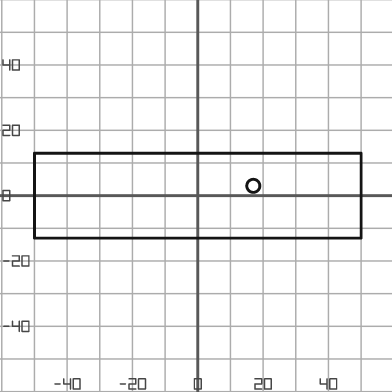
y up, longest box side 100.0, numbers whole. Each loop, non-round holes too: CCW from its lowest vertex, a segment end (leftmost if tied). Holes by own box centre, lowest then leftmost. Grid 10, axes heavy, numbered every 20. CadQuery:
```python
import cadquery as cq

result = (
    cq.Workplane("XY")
    .moveTo(-50.0, -13.0)
    .lineTo(50.0, -13.0)
    .lineTo(50.0, 13.0)
    .lineTo(-50.0, 13.0)
    .close()
    .moveTo(17.0, 3.0)
    .circle(2.0)
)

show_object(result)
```